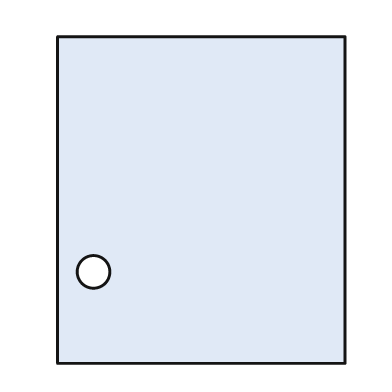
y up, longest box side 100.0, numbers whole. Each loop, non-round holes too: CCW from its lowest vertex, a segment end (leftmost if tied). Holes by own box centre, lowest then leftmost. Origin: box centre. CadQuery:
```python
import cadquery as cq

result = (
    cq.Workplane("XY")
    .moveTo(-44.0, -50.0)
    .lineTo(44.0, -50.0)
    .lineTo(44.0, 50.0)
    .lineTo(-44.0, 50.0)
    .close()
    .moveTo(-33.0, -22.0)
    .circle(5.0)
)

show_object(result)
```